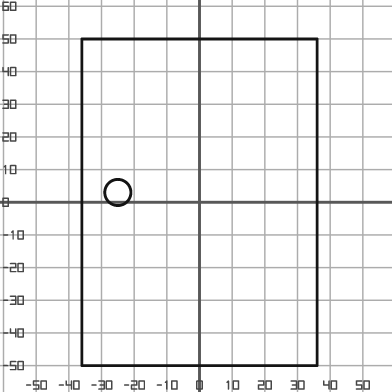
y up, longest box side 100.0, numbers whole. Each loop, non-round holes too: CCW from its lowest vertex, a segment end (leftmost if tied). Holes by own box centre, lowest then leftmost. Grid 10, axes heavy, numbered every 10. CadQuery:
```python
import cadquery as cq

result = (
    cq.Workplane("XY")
    .moveTo(-36.0, -50.0)
    .lineTo(36.0, -50.0)
    .lineTo(36.0, 50.0)
    .lineTo(-36.0, 50.0)
    .close()
    .moveTo(-25.0, 3.0)
    .circle(4.0)
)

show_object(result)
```